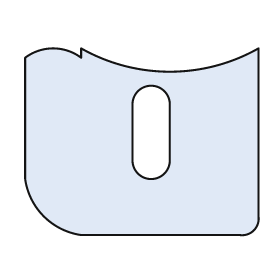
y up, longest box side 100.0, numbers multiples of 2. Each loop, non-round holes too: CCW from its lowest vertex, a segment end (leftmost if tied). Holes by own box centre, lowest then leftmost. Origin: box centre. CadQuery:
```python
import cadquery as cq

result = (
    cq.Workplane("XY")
    .moveTo(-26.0, -40.0)
    .lineTo(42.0, -40.0)
    .threePointArc((48.0, -38.0), (50.0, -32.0))
    .lineTo(50.0, 40.0)
    .threePointArc((12.0, 30.0), (-26.0, 40.0))
    .lineTo(-26.0, 36.0)
    .threePointArc((-38.0, 40.0), (-50.0, 36.0))
    .lineTo(-50.0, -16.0)
    .threePointArc((-42.0, -32.0), (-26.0, -40.0))
    .close()
    .moveTo(-4.0, -8.0)
    .threePointArc((4.0, -16.0), (12.0, -8.0))
    .lineTo(12.0, 16.0)
    .threePointArc((4.0, 24.0), (-4.0, 16.0))
    .close()
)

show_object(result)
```